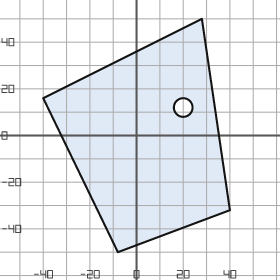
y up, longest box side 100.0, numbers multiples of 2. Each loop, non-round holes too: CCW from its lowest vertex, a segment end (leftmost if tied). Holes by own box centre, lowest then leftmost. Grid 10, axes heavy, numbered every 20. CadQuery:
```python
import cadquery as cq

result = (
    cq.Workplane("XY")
    .moveTo(-8.0, -50.0)
    .lineTo(40.0, -32.0)
    .lineTo(28.0, 50.0)
    .lineTo(-40.0, 16.0)
    .close()
    .moveTo(20.0, 12.0)
    .circle(4.0)
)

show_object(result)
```